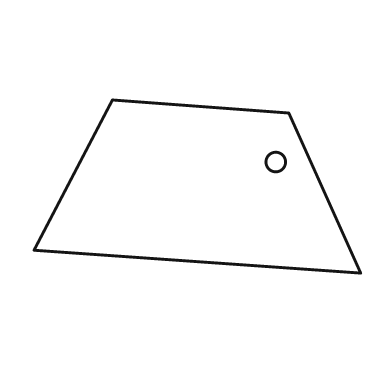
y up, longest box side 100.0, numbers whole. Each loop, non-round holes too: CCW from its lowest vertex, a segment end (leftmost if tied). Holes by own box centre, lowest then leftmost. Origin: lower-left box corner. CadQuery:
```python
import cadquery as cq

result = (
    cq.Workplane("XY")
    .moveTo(100.0, 0.0)
    .lineTo(78.0, 49.0)
    .lineTo(24.0, 53.0)
    .lineTo(0.0, 7.0)
    .close()
    .moveTo(74.0, 34.0)
    .circle(3.0)
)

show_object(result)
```